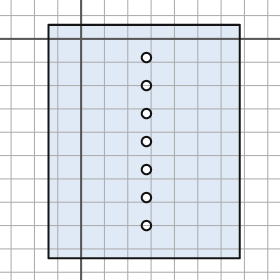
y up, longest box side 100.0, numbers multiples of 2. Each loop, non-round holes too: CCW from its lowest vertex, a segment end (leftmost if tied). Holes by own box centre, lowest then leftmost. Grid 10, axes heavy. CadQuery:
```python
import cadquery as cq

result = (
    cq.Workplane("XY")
    .moveTo(-14.0, -94.0)
    .lineTo(68.0, -94.0)
    .lineTo(68.0, 6.0)
    .lineTo(-14.0, 6.0)
    .close()
    .moveTo(28.0, -80.0)
    .circle(2.0)
    .moveTo(28.0, -68.0)
    .circle(2.0)
    .moveTo(28.0, -56.0)
    .circle(2.0)
    .moveTo(28.0, -44.0)
    .circle(2.0)
    .moveTo(28.0, -32.0)
    .circle(2.0)
    .moveTo(28.0, -20.0)
    .circle(2.0)
    .moveTo(28.0, -8.0)
    .circle(2.0)
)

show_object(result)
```